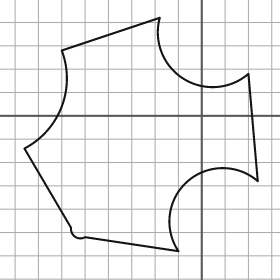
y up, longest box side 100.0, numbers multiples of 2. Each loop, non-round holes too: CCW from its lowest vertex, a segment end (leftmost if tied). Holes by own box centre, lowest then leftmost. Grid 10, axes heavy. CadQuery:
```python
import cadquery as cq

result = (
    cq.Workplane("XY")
    .moveTo(-10.0, -58.0)
    .threePointArc((-6.0, -28.0), (24.0, -28.0))
    .lineTo(20.0, 18.0)
    .threePointArc((-8.0, 16.0), (-18.0, 42.0))
    .lineTo(-60.0, 28.0)
    .threePointArc((-60.0, 4.0), (-76.0, -14.0))
    .lineTo(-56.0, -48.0)
    .threePointArc((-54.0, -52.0), (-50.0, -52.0))
    .close()
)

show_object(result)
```